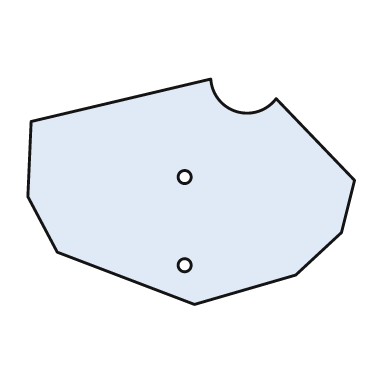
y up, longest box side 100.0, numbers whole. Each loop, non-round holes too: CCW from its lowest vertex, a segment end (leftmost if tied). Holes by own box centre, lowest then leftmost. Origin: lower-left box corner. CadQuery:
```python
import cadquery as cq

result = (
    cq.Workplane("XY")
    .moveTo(51.0, 0.0)
    .lineTo(82.0, 9.0)
    .lineTo(96.0, 22.0)
    .lineTo(100.0, 38.0)
    .lineTo(76.0, 63.0)
    .threePointArc((64.0, 59.0), (56.0, 69.0))
    .lineTo(1.0, 56.0)
    .lineTo(0.0, 33.0)
    .lineTo(9.0, 16.0)
    .close()
    .moveTo(48.0, 12.0)
    .circle(2.0)
    .moveTo(48.0, 39.0)
    .circle(2.0)
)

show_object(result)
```